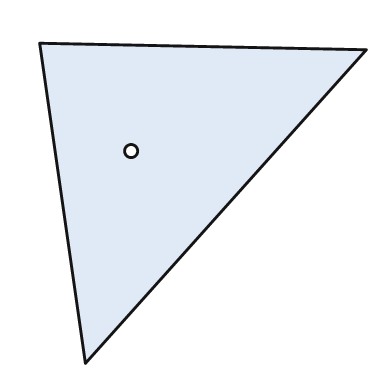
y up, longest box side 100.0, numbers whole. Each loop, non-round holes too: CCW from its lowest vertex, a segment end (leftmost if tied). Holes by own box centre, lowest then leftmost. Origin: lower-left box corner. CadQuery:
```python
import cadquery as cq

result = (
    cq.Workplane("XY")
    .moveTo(14.0, 0.0)
    .lineTo(100.0, 96.0)
    .lineTo(0.0, 98.0)
    .close()
    .moveTo(28.0, 65.0)
    .circle(2.0)
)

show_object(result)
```